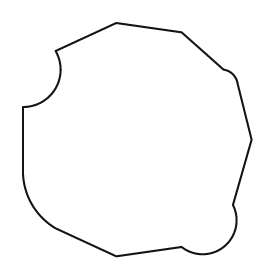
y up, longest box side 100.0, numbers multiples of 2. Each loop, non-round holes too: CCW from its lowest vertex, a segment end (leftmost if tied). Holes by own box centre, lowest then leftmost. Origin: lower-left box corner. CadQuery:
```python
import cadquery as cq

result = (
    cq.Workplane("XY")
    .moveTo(40.0, 0.0)
    .lineTo(68.0, 4.0)
    .threePointArc((86.0, 4.0), (90.0, 22.0))
    .lineTo(98.0, 50.0)
    .lineTo(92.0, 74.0)
    .threePointArc((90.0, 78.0), (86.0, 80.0))
    .lineTo(68.0, 96.0)
    .lineTo(40.0, 100.0)
    .lineTo(14.0, 88.0)
    .threePointArc((14.0, 72.0), (0.0, 64.0))
    .lineTo(0.0, 36.0)
    .threePointArc((4.0, 22.0), (14.0, 12.0))
    .close()
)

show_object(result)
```